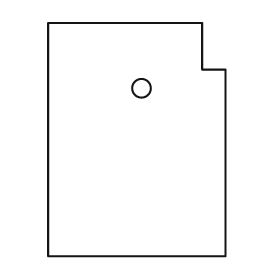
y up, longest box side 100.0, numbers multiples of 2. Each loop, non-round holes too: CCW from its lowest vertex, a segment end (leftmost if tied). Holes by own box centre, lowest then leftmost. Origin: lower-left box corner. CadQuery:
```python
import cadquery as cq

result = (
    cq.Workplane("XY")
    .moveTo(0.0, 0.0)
    .lineTo(76.0, 0.0)
    .lineTo(76.0, 80.0)
    .lineTo(66.0, 80.0)
    .lineTo(66.0, 100.0)
    .lineTo(0.0, 100.0)
    .close()
    .moveTo(40.0, 72.0)
    .circle(4.0)
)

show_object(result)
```